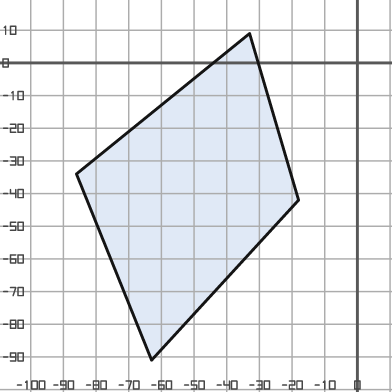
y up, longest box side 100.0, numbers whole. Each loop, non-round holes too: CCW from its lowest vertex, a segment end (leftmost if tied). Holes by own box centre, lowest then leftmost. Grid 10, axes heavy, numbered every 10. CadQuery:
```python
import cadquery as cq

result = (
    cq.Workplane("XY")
    .moveTo(-63.0, -91.0)
    .lineTo(-18.0, -42.0)
    .lineTo(-33.0, 9.0)
    .lineTo(-86.0, -34.0)
    .close()
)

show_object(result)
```